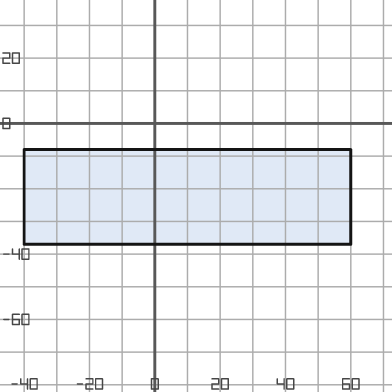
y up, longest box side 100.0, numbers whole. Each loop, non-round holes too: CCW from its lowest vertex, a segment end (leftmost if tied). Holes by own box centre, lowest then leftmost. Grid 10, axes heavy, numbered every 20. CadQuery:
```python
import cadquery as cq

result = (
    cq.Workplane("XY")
    .moveTo(-40.0, -37.0)
    .lineTo(60.0, -37.0)
    .lineTo(60.0, -8.0)
    .lineTo(-40.0, -8.0)
    .close()
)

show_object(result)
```